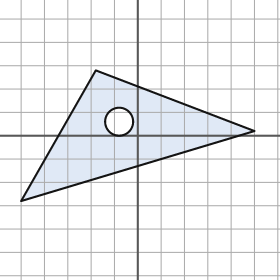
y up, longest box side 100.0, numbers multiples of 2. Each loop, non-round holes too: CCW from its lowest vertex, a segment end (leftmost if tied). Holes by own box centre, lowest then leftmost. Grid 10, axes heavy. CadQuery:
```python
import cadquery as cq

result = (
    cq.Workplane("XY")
    .moveTo(-50.0, -28.0)
    .lineTo(50.0, 2.0)
    .lineTo(-18.0, 28.0)
    .close()
    .moveTo(-8.0, 6.0)
    .circle(6.0)
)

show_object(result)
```